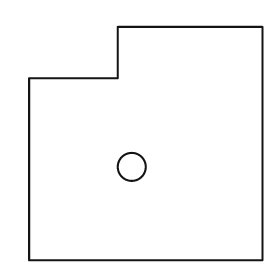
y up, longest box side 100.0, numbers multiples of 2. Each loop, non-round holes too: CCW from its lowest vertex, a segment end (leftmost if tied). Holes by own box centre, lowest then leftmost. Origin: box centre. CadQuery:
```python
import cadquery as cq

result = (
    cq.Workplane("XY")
    .moveTo(-50.0, -50.0)
    .lineTo(50.0, -50.0)
    .lineTo(50.0, 50.0)
    .lineTo(-12.0, 50.0)
    .lineTo(-12.0, 28.0)
    .lineTo(-50.0, 28.0)
    .close()
    .moveTo(-6.0, -10.0)
    .circle(6.0)
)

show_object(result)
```